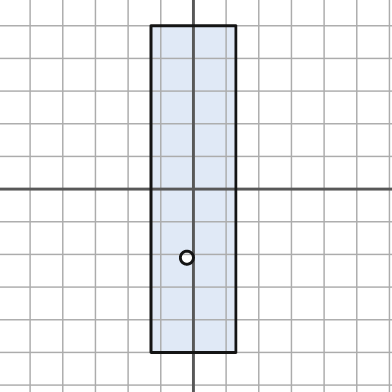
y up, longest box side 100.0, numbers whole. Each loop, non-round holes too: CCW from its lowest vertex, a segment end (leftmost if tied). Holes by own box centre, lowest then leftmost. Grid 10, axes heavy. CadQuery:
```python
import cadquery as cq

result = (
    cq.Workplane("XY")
    .moveTo(-13.0, -50.0)
    .lineTo(13.0, -50.0)
    .lineTo(13.0, 50.0)
    .lineTo(-13.0, 50.0)
    .close()
    .moveTo(-2.0, -21.0)
    .circle(2.0)
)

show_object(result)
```